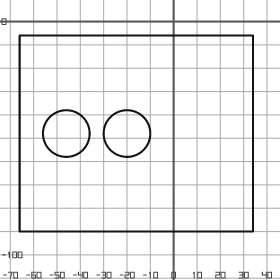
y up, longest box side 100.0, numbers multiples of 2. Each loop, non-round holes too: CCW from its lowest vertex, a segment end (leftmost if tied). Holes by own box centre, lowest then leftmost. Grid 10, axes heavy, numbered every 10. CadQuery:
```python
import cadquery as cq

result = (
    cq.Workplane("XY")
    .moveTo(-66.0, -90.0)
    .lineTo(34.0, -90.0)
    .lineTo(34.0, -6.0)
    .lineTo(-66.0, -6.0)
    .close()
    .moveTo(-46.0, -48.0)
    .circle(10.0)
    .moveTo(-20.0, -48.0)
    .circle(10.0)
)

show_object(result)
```